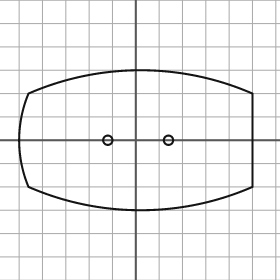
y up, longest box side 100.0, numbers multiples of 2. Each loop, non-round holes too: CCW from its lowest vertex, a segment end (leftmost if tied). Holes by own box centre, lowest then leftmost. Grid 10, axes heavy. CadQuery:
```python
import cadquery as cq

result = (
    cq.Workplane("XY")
    .moveTo(-46.0, -20.0)
    .threePointArc((2.0, -30.0), (50.0, -20.0))
    .lineTo(50.0, 20.0)
    .threePointArc((2.0, 30.0), (-46.0, 20.0))
    .threePointArc((-50.0, 0.0), (-46.0, -20.0))
    .close()
    .moveTo(-12.0, 0.0)
    .circle(2.0)
    .moveTo(14.0, 0.0)
    .circle(2.0)
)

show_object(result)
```